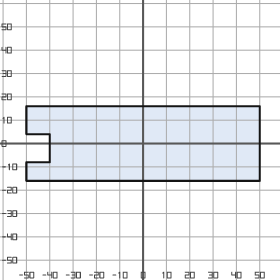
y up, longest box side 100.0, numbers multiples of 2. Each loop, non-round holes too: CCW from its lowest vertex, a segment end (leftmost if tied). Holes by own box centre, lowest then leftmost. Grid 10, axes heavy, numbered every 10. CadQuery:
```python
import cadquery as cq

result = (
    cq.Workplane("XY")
    .moveTo(-50.0, -16.0)
    .lineTo(50.0, -16.0)
    .lineTo(50.0, 16.0)
    .lineTo(-50.0, 16.0)
    .lineTo(-50.0, 4.0)
    .lineTo(-40.0, 4.0)
    .lineTo(-40.0, -8.0)
    .lineTo(-50.0, -8.0)
    .close()
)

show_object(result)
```